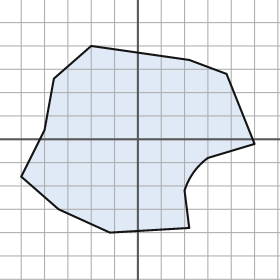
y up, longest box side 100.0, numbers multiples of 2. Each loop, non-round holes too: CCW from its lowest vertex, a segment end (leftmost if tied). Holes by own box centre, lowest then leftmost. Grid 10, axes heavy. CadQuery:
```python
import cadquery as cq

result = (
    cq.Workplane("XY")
    .moveTo(-12.0, -40.0)
    .lineTo(22.0, -38.0)
    .lineTo(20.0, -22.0)
    .threePointArc((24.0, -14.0), (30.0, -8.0))
    .lineTo(50.0, -2.0)
    .lineTo(38.0, 28.0)
    .lineTo(22.0, 34.0)
    .lineTo(-20.0, 40.0)
    .lineTo(-36.0, 26.0)
    .lineTo(-40.0, 4.0)
    .lineTo(-50.0, -16.0)
    .lineTo(-34.0, -30.0)
    .close()
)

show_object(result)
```